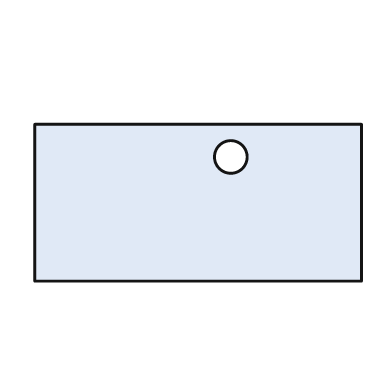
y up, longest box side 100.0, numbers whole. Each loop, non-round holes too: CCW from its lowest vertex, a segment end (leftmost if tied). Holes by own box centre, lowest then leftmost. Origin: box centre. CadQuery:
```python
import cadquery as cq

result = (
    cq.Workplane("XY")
    .moveTo(-50.0, -24.0)
    .lineTo(50.0, -24.0)
    .lineTo(50.0, 24.0)
    .lineTo(-50.0, 24.0)
    .close()
    .moveTo(10.0, 14.0)
    .circle(5.0)
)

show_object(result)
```